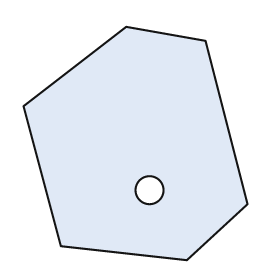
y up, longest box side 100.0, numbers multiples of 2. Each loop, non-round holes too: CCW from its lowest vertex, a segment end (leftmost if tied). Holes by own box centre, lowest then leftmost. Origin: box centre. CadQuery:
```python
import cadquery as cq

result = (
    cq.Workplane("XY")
    .moveTo(22.0, -50.0)
    .lineTo(48.0, -26.0)
    .lineTo(30.0, 44.0)
    .lineTo(-4.0, 50.0)
    .lineTo(-48.0, 16.0)
    .lineTo(-32.0, -44.0)
    .close()
    .moveTo(6.0, -20.0)
    .circle(6.0)
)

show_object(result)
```